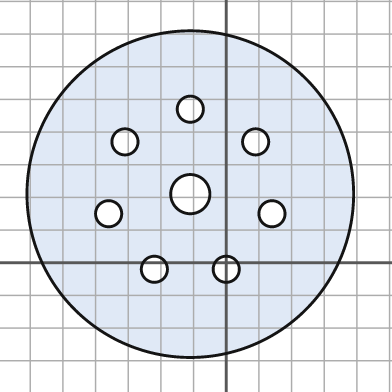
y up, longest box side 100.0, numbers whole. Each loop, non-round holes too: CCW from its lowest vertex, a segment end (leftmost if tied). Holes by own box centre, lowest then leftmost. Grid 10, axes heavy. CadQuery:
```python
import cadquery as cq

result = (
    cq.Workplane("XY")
    .moveTo(-11.0, 21.0)
    .circle(50.0)
    .moveTo(-22.0, -2.0)
    .circle(4.0)
    .moveTo(0.0, -2.0)
    .circle(4.0)
    .moveTo(-36.0, 15.0)
    .circle(4.0)
    .moveTo(14.0, 15.0)
    .circle(4.0)
    .moveTo(-11.0, 21.0)
    .circle(6.0)
    .moveTo(-31.0, 37.0)
    .circle(4.0)
    .moveTo(9.0, 37.0)
    .circle(4.0)
    .moveTo(-11.0, 47.0)
    .circle(4.0)
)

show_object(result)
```